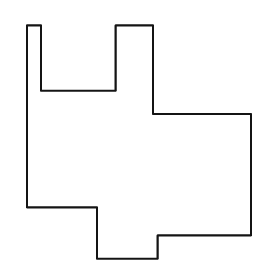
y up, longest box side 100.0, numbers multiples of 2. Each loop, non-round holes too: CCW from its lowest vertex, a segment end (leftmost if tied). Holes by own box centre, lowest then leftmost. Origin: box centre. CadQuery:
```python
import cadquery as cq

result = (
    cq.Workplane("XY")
    .moveTo(-18.0, -50.0)
    .lineTo(8.0, -50.0)
    .lineTo(8.0, -40.0)
    .lineTo(48.0, -40.0)
    .lineTo(48.0, 12.0)
    .lineTo(6.0, 12.0)
    .lineTo(6.0, 50.0)
    .lineTo(-10.0, 50.0)
    .lineTo(-10.0, 22.0)
    .lineTo(-42.0, 22.0)
    .lineTo(-42.0, 50.0)
    .lineTo(-48.0, 50.0)
    .lineTo(-48.0, -28.0)
    .lineTo(-18.0, -28.0)
    .close()
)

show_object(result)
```